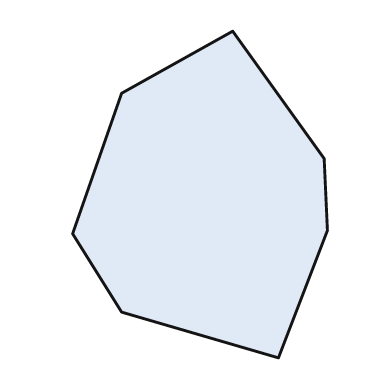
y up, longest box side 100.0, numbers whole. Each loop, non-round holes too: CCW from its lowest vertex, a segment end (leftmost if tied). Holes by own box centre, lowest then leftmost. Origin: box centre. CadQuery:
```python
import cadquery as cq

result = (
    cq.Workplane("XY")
    .moveTo(24.0, -50.0)
    .lineTo(39.0, -11.0)
    .lineTo(38.0, 11.0)
    .lineTo(10.0, 50.0)
    .lineTo(-24.0, 31.0)
    .lineTo(-39.0, -12.0)
    .lineTo(-24.0, -36.0)
    .close()
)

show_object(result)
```